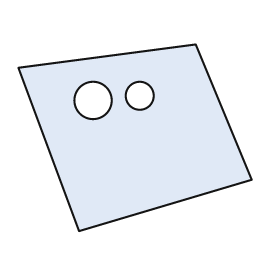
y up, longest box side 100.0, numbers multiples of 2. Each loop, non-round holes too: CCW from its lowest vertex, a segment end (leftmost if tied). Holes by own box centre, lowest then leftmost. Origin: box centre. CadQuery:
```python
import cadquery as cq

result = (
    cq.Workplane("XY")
    .moveTo(-24.0, -40.0)
    .lineTo(50.0, -18.0)
    .lineTo(26.0, 40.0)
    .lineTo(-50.0, 30.0)
    .close()
    .moveTo(-18.0, 16.0)
    .circle(8.0)
    .moveTo(2.0, 18.0)
    .circle(6.0)
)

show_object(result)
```